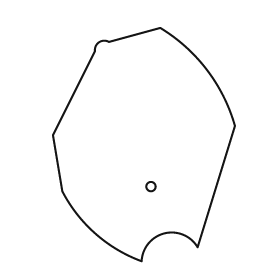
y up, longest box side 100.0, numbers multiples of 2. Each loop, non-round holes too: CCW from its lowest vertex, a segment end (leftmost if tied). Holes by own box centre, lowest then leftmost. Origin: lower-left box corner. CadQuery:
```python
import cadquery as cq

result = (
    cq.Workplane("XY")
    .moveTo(38.0, 0.0)
    .threePointArc((48.0, 12.0), (62.0, 6.0))
    .lineTo(78.0, 58.0)
    .threePointArc((66.0, 82.0), (46.0, 100.0))
    .lineTo(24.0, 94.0)
    .threePointArc((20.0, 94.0), (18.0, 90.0))
    .lineTo(0.0, 54.0)
    .lineTo(4.0, 30.0)
    .threePointArc((18.0, 12.0), (38.0, 0.0))
    .close()
    .moveTo(42.0, 32.0)
    .circle(2.0)
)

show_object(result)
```